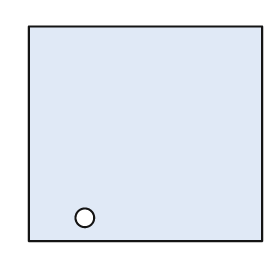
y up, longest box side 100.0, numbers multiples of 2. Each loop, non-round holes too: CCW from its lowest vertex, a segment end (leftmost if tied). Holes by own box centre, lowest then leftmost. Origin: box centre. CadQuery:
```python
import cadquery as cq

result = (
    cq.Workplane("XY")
    .moveTo(-50.0, -46.0)
    .lineTo(50.0, -46.0)
    .lineTo(50.0, 46.0)
    .lineTo(-50.0, 46.0)
    .close()
    .moveTo(-26.0, -36.0)
    .circle(4.0)
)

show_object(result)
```